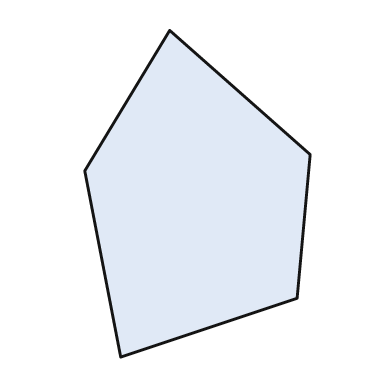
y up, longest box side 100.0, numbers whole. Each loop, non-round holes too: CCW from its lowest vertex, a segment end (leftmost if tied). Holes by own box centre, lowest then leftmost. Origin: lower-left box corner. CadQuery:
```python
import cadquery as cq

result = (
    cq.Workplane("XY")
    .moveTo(11.0, 0.0)
    .lineTo(65.0, 18.0)
    .lineTo(69.0, 62.0)
    .lineTo(26.0, 100.0)
    .lineTo(0.0, 57.0)
    .close()
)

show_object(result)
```